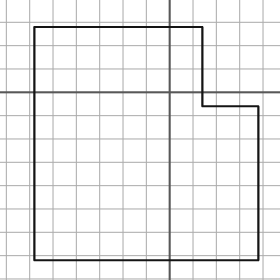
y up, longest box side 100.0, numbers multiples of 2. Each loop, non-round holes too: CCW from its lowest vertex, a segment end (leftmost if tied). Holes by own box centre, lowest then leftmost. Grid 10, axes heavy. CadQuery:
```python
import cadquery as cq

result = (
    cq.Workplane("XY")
    .moveTo(-58.0, -72.0)
    .lineTo(38.0, -72.0)
    .lineTo(38.0, -6.0)
    .lineTo(14.0, -6.0)
    .lineTo(14.0, 28.0)
    .lineTo(-58.0, 28.0)
    .close()
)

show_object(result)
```